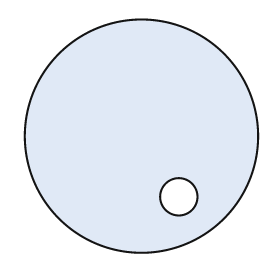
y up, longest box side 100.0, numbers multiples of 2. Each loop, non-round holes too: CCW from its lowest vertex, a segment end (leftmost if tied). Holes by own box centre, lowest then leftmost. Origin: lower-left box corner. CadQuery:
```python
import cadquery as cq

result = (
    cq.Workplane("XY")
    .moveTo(50.0, 50.0)
    .circle(50.0)
    .moveTo(66.0, 24.0)
    .circle(8.0)
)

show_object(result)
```